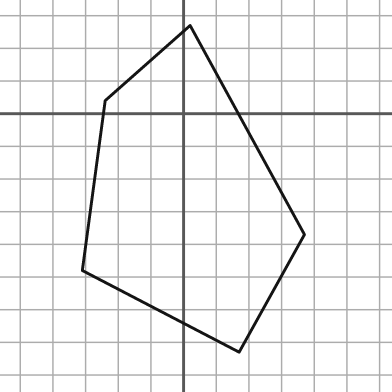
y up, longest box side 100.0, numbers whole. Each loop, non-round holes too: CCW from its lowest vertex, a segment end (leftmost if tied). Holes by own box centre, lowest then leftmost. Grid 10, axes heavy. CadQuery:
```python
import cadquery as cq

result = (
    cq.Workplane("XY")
    .moveTo(17.0, -73.0)
    .lineTo(37.0, -37.0)
    .lineTo(2.0, 27.0)
    .lineTo(-24.0, 4.0)
    .lineTo(-31.0, -48.0)
    .close()
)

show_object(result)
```